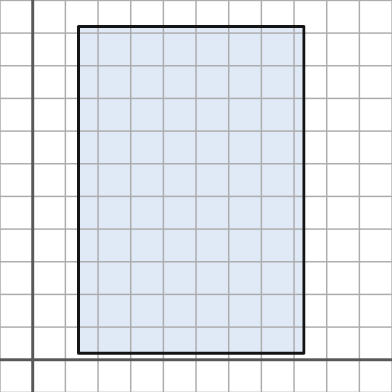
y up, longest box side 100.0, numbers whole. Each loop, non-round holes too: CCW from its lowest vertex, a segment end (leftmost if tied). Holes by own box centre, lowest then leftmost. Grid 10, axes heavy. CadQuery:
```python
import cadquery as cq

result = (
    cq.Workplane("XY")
    .moveTo(14.0, 2.0)
    .lineTo(83.0, 2.0)
    .lineTo(83.0, 102.0)
    .lineTo(14.0, 102.0)
    .close()
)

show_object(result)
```